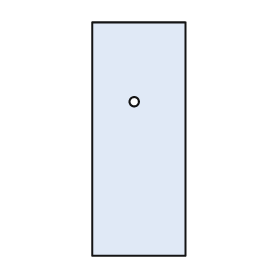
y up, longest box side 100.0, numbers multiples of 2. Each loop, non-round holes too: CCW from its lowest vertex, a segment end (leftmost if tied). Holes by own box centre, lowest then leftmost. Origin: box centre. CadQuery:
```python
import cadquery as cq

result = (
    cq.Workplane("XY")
    .moveTo(-20.0, -50.0)
    .lineTo(20.0, -50.0)
    .lineTo(20.0, 50.0)
    .lineTo(-20.0, 50.0)
    .close()
    .moveTo(-2.0, 16.0)
    .circle(2.0)
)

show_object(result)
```